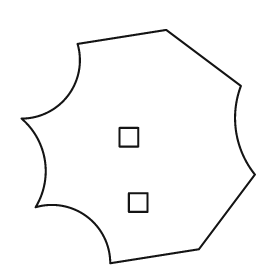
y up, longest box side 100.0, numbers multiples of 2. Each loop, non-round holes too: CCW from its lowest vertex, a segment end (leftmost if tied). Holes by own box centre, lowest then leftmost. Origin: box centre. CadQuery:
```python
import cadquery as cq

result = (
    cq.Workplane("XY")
    .moveTo(-12.0, -50.0)
    .lineTo(26.0, -44.0)
    .lineTo(50.0, -12.0)
    .threePointArc((42.0, 6.0), (44.0, 26.0))
    .lineTo(12.0, 50.0)
    .lineTo(-26.0, 44.0)
    .threePointArc((-30.0, 22.0), (-50.0, 12.0))
    .threePointArc((-40.0, -6.0), (-44.0, -26.0))
    .threePointArc((-22.0, -30.0), (-12.0, -50.0))
    .close()
    .moveTo(-4.0, -28.0)
    .lineTo(4.0, -28.0)
    .lineTo(4.0, -20.0)
    .lineTo(-4.0, -20.0)
    .close()
    .moveTo(-8.0, 0.0)
    .lineTo(0.0, 0.0)
    .lineTo(0.0, 8.0)
    .lineTo(-8.0, 8.0)
    .close()
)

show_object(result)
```